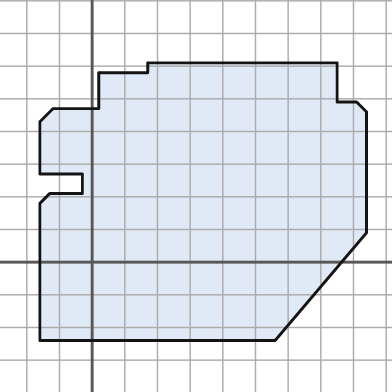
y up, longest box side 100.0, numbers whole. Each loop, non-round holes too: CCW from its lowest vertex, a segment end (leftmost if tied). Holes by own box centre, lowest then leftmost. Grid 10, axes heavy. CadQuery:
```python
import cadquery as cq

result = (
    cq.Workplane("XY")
    .moveTo(-16.0, -24.0)
    .lineTo(56.0, -24.0)
    .lineTo(84.0, 9.0)
    .lineTo(84.0, 46.0)
    .lineTo(81.0, 49.0)
    .lineTo(75.0, 49.0)
    .lineTo(75.0, 61.0)
    .lineTo(17.0, 61.0)
    .lineTo(17.0, 58.0)
    .lineTo(2.0, 58.0)
    .lineTo(2.0, 47.0)
    .lineTo(-12.0, 47.0)
    .lineTo(-16.0, 43.0)
    .lineTo(-16.0, 27.0)
    .lineTo(-3.0, 27.0)
    .lineTo(-3.0, 21.0)
    .lineTo(-13.0, 21.0)
    .lineTo(-16.0, 18.0)
    .close()
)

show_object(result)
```